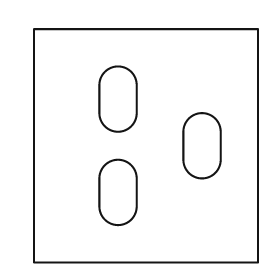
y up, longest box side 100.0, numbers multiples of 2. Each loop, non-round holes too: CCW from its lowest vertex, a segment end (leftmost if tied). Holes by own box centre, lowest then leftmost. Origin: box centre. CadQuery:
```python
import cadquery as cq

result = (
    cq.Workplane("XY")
    .moveTo(-48.0, -50.0)
    .lineTo(48.0, -50.0)
    .lineTo(48.0, 50.0)
    .lineTo(-48.0, 50.0)
    .close()
    .moveTo(-20.0, -26.0)
    .threePointArc((-12.0, -34.0), (-4.0, -26.0))
    .lineTo(-4.0, -14.0)
    .threePointArc((-12.0, -6.0), (-20.0, -14.0))
    .close()
    .moveTo(16.0, -6.0)
    .threePointArc((24.0, -14.0), (32.0, -6.0))
    .lineTo(32.0, 6.0)
    .threePointArc((24.0, 14.0), (16.0, 6.0))
    .close()
    .moveTo(-20.0, 14.0)
    .threePointArc((-12.0, 6.0), (-4.0, 14.0))
    .lineTo(-4.0, 26.0)
    .threePointArc((-12.0, 34.0), (-20.0, 26.0))
    .close()
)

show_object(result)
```